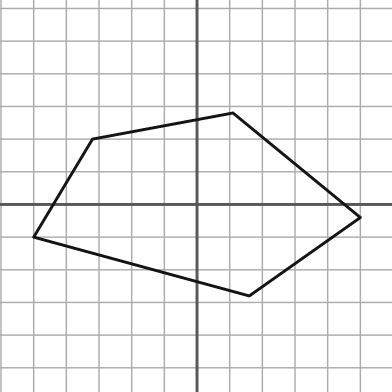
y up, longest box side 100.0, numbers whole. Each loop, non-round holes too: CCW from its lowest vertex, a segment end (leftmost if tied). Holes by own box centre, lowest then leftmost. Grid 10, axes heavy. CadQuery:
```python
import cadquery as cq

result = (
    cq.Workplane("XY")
    .moveTo(16.0, -28.0)
    .lineTo(50.0, -4.0)
    .lineTo(11.0, 28.0)
    .lineTo(-32.0, 20.0)
    .lineTo(-50.0, -10.0)
    .close()
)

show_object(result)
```